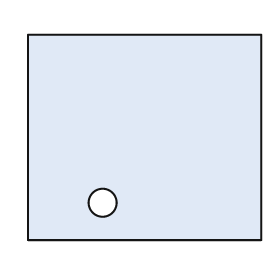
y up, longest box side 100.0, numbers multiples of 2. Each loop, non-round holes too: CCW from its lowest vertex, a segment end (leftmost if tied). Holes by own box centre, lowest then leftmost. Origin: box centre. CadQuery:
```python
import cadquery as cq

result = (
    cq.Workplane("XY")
    .moveTo(-50.0, -44.0)
    .lineTo(50.0, -44.0)
    .lineTo(50.0, 44.0)
    .lineTo(-50.0, 44.0)
    .close()
    .moveTo(-18.0, -28.0)
    .circle(6.0)
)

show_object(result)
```